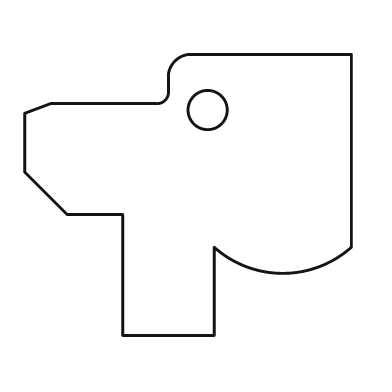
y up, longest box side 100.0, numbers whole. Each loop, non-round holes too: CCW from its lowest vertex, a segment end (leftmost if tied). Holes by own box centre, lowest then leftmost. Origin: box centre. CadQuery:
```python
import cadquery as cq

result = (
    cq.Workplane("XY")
    .moveTo(-20.0, -43.0)
    .lineTo(8.0, -43.0)
    .lineTo(8.0, -16.0)
    .threePointArc((29.0, -24.0), (50.0, -16.0))
    .lineTo(50.0, 43.0)
    .lineTo(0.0, 43.0)
    .threePointArc((-4.0, 41.0), (-6.0, 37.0))
    .lineTo(-6.0, 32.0)
    .threePointArc((-7.0, 29.0), (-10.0, 28.0))
    .lineTo(-42.0, 28.0)
    .lineTo(-50.0, 25.0)
    .lineTo(-50.0, 7.0)
    .lineTo(-37.0, -6.0)
    .lineTo(-20.0, -6.0)
    .close()
    .moveTo(6.0, 26.0)
    .circle(6.0)
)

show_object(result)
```